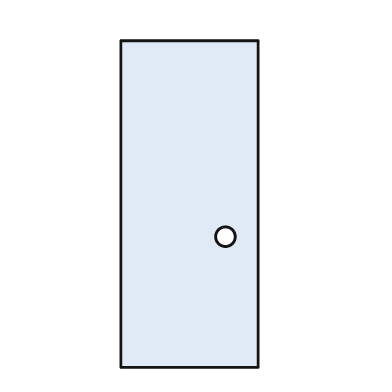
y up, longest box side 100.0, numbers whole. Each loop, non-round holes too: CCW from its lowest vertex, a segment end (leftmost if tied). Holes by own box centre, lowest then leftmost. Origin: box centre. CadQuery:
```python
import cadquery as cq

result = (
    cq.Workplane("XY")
    .moveTo(-21.0, -50.0)
    .lineTo(21.0, -50.0)
    .lineTo(21.0, 50.0)
    .lineTo(-21.0, 50.0)
    .close()
    .moveTo(11.0, -10.0)
    .circle(3.0)
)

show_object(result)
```